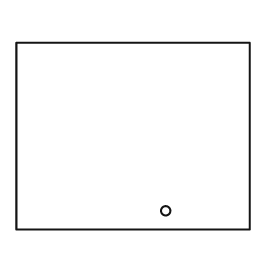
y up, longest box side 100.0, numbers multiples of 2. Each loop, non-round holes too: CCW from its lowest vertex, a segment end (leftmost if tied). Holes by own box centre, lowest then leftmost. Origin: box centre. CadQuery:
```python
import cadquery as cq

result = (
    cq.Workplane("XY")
    .moveTo(-50.0, -40.0)
    .lineTo(50.0, -40.0)
    .lineTo(50.0, 40.0)
    .lineTo(-50.0, 40.0)
    .close()
    .moveTo(14.0, -32.0)
    .circle(2.0)
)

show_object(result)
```